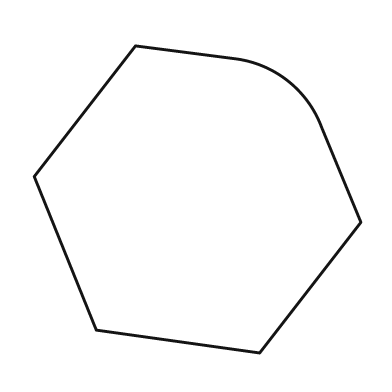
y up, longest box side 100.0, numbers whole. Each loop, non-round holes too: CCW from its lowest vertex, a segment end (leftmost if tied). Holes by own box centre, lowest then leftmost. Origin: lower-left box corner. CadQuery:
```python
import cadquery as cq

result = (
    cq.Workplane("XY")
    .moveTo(69.0, 0.0)
    .lineTo(100.0, 40.0)
    .lineTo(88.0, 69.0)
    .threePointArc((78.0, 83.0), (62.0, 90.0))
    .lineTo(31.0, 94.0)
    .lineTo(0.0, 54.0)
    .lineTo(19.0, 7.0)
    .close()
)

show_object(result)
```